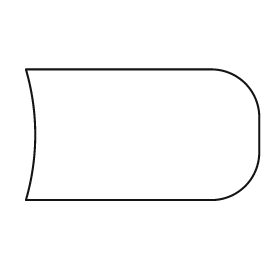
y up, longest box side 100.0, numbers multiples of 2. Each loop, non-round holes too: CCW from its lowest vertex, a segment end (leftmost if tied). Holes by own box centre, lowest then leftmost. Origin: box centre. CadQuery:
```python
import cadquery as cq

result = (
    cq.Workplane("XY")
    .moveTo(-50.0, -28.0)
    .lineTo(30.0, -28.0)
    .threePointArc((44.0, -22.0), (50.0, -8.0))
    .lineTo(50.0, 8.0)
    .threePointArc((44.0, 22.0), (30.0, 28.0))
    .lineTo(-50.0, 28.0)
    .threePointArc((-46.0, 0.0), (-50.0, -28.0))
    .close()
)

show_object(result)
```